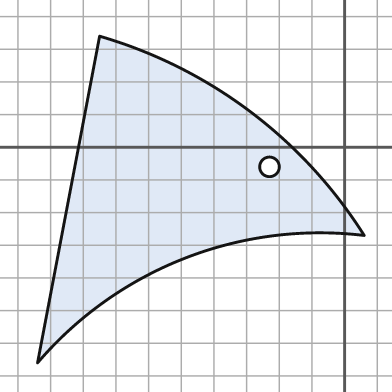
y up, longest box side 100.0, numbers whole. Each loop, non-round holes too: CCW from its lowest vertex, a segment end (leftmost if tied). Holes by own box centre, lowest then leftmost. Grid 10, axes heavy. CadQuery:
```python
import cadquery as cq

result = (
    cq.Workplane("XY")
    .moveTo(-94.0, -66.0)
    .threePointArc((-49.0, -34.0), (6.0, -27.0))
    .threePointArc((-29.0, 11.0), (-75.0, 34.0))
    .close()
    .moveTo(-23.0, -6.0)
    .circle(3.0)
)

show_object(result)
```